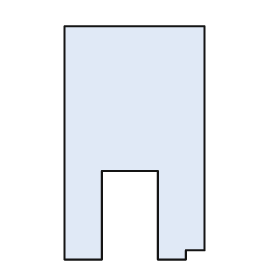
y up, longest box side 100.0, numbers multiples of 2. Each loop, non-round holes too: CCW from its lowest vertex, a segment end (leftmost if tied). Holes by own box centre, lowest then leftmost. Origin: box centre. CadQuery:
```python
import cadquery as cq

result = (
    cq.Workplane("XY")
    .moveTo(-30.0, -50.0)
    .lineTo(-14.0, -50.0)
    .lineTo(-14.0, -12.0)
    .lineTo(10.0, -12.0)
    .lineTo(10.0, -50.0)
    .lineTo(22.0, -50.0)
    .lineTo(22.0, -46.0)
    .lineTo(30.0, -46.0)
    .lineTo(30.0, 50.0)
    .lineTo(-30.0, 50.0)
    .close()
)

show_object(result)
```